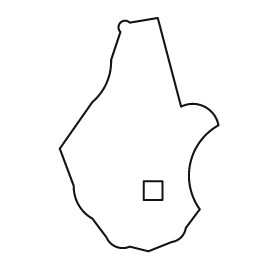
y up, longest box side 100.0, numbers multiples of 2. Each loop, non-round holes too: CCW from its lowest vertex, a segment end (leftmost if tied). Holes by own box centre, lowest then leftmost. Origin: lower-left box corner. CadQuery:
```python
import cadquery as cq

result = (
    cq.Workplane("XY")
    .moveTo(38.0, 0.0)
    .lineTo(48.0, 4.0)
    .threePointArc((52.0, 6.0), (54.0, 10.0))
    .lineTo(60.0, 18.0)
    .threePointArc((56.0, 38.0), (68.0, 54.0))
    .threePointArc((62.0, 62.0), (52.0, 62.0))
    .lineTo(42.0, 100.0)
    .lineTo(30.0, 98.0)
    .threePointArc((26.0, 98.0), (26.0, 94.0))
    .lineTo(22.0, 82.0)
    .threePointArc((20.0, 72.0), (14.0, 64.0))
    .lineTo(0.0, 44.0)
    .lineTo(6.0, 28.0)
    .threePointArc((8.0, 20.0), (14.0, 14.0))
    .lineTo(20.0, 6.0)
    .threePointArc((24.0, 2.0), (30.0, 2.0))
    .close()
    .moveTo(36.0, 22.0)
    .lineTo(44.0, 22.0)
    .lineTo(44.0, 30.0)
    .lineTo(36.0, 30.0)
    .close()
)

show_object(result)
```